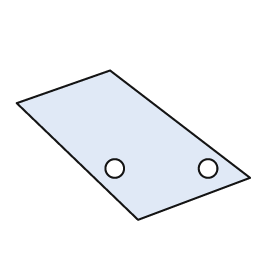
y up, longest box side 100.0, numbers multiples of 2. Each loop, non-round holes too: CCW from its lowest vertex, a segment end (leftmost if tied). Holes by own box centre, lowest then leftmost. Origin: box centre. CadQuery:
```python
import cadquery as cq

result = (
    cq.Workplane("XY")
    .moveTo(2.0, -32.0)
    .lineTo(50.0, -14.0)
    .lineTo(-10.0, 32.0)
    .lineTo(-50.0, 18.0)
    .close()
    .moveTo(-8.0, -10.0)
    .circle(4.0)
    .moveTo(32.0, -10.0)
    .circle(4.0)
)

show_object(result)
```